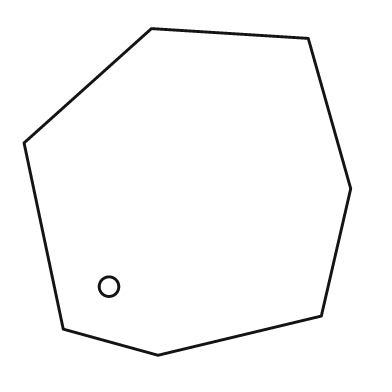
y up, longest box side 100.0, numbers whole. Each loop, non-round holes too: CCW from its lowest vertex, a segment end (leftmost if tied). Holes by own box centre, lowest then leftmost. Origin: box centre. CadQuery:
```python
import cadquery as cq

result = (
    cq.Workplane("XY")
    .moveTo(-9.0, -50.0)
    .lineTo(41.0, -38.0)
    .lineTo(50.0, 1.0)
    .lineTo(37.0, 47.0)
    .lineTo(-11.0, 50.0)
    .lineTo(-50.0, 15.0)
    .lineTo(-38.0, -42.0)
    .close()
    .moveTo(-24.0, -29.0)
    .circle(3.0)
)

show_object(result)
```